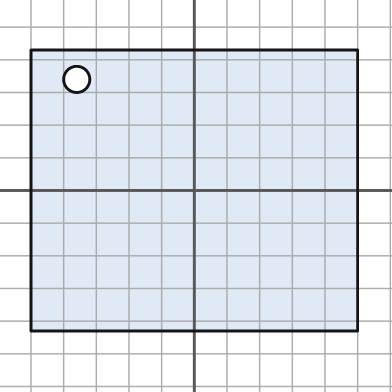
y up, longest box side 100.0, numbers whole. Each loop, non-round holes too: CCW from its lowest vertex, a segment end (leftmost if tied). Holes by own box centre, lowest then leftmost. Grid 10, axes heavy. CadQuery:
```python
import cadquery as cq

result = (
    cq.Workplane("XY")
    .moveTo(-50.0, -43.0)
    .lineTo(50.0, -43.0)
    .lineTo(50.0, 43.0)
    .lineTo(-50.0, 43.0)
    .close()
    .moveTo(-36.0, 34.0)
    .circle(4.0)
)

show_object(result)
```